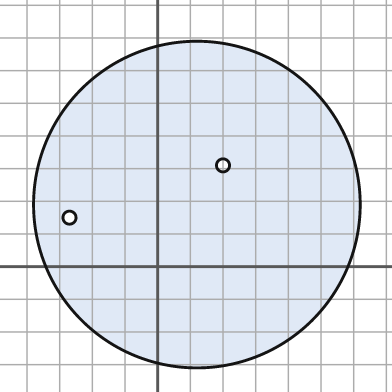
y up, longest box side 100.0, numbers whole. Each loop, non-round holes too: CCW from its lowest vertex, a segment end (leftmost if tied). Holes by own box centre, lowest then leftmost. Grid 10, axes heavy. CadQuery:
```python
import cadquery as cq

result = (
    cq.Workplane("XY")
    .moveTo(12.0, 19.0)
    .circle(50.0)
    .moveTo(-27.0, 15.0)
    .circle(2.0)
    .moveTo(20.0, 31.0)
    .circle(2.0)
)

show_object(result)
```